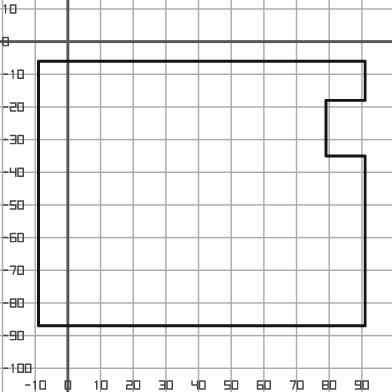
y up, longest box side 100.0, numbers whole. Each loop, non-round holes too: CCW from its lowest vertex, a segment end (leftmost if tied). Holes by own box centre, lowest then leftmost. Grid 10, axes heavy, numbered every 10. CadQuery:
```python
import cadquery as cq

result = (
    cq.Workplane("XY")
    .moveTo(-9.0, -87.0)
    .lineTo(91.0, -87.0)
    .lineTo(91.0, -35.0)
    .lineTo(79.0, -35.0)
    .lineTo(79.0, -18.0)
    .lineTo(91.0, -18.0)
    .lineTo(91.0, -6.0)
    .lineTo(-9.0, -6.0)
    .close()
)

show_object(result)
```